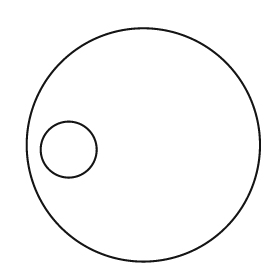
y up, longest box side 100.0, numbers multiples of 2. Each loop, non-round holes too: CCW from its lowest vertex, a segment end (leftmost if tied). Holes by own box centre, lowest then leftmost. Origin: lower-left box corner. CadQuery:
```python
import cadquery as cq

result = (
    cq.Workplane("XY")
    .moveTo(50.0, 50.0)
    .circle(50.0)
    .moveTo(18.0, 48.0)
    .circle(12.0)
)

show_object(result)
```